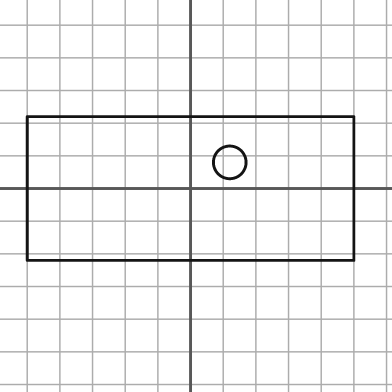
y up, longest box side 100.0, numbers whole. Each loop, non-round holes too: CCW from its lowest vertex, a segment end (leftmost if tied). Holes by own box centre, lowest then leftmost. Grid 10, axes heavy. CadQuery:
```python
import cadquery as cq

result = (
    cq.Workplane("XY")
    .moveTo(-50.0, -22.0)
    .lineTo(50.0, -22.0)
    .lineTo(50.0, 22.0)
    .lineTo(-50.0, 22.0)
    .close()
    .moveTo(12.0, 8.0)
    .circle(5.0)
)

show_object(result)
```